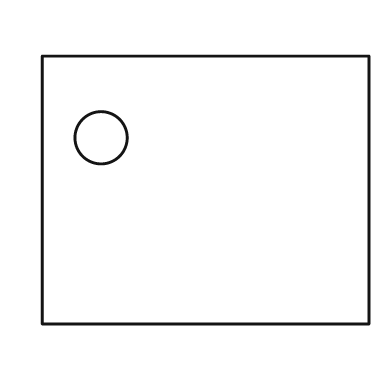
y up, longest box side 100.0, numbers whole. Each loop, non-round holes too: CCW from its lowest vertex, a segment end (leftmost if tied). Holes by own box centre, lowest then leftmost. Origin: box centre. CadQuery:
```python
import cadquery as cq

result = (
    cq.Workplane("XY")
    .moveTo(-50.0, -41.0)
    .lineTo(50.0, -41.0)
    .lineTo(50.0, 41.0)
    .lineTo(-50.0, 41.0)
    .close()
    .moveTo(-32.0, 16.0)
    .circle(8.0)
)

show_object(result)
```